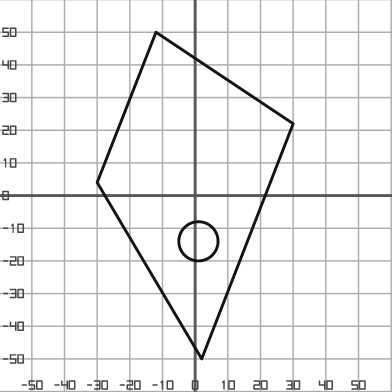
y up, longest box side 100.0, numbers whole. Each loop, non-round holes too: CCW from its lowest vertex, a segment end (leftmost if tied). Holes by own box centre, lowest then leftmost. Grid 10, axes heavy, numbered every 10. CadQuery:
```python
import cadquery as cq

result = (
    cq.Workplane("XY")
    .moveTo(2.0, -50.0)
    .lineTo(30.0, 22.0)
    .lineTo(-12.0, 50.0)
    .lineTo(-30.0, 4.0)
    .close()
    .moveTo(1.0, -14.0)
    .circle(6.0)
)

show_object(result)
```